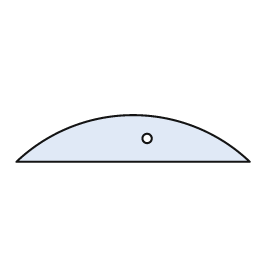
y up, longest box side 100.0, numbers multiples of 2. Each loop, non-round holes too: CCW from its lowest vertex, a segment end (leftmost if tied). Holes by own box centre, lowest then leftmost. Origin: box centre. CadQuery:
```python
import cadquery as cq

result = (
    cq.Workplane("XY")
    .moveTo(-50.0, -10.0)
    .lineTo(50.0, -10.0)
    .threePointArc((0.0, 10.0), (-50.0, -10.0))
    .close()
    .moveTo(6.0, 0.0)
    .circle(2.0)
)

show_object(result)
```